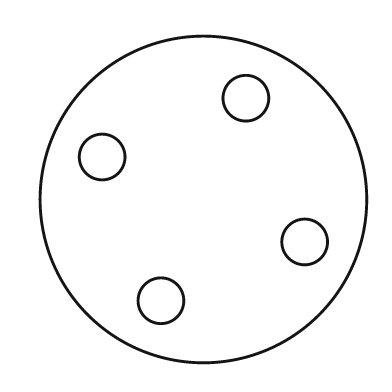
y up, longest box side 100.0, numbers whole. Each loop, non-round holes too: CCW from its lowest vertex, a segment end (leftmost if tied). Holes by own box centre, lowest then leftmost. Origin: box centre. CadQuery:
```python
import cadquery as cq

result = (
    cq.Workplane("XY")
    .moveTo(0.0, 0.0)
    .circle(50.0)
    .moveTo(-13.0, -31.0)
    .circle(7.0)
    .moveTo(31.0, -13.0)
    .circle(7.0)
    .moveTo(-31.0, 13.0)
    .circle(7.0)
    .moveTo(13.0, 31.0)
    .circle(7.0)
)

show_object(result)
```